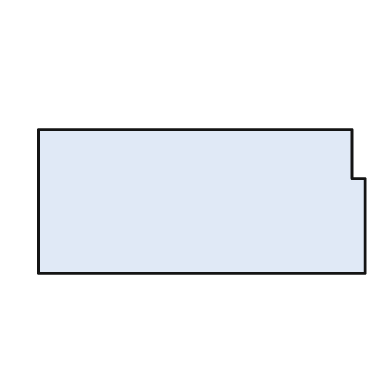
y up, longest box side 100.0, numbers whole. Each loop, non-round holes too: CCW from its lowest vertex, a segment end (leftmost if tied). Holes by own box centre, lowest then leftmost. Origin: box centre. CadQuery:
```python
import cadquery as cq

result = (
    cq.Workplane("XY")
    .moveTo(-50.0, -22.0)
    .lineTo(50.0, -22.0)
    .lineTo(50.0, 7.0)
    .lineTo(46.0, 7.0)
    .lineTo(46.0, 22.0)
    .lineTo(-50.0, 22.0)
    .close()
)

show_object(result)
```